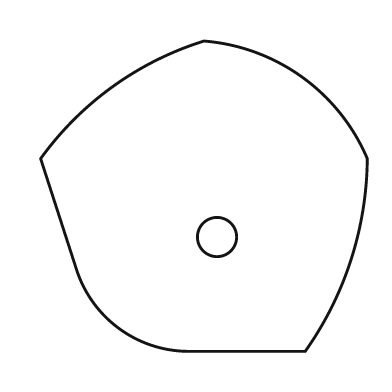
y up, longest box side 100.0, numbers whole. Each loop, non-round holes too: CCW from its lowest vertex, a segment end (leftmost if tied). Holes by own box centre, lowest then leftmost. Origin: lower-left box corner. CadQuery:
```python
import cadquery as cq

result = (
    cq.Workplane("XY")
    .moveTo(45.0, 0.0)
    .lineTo(81.0, 0.0)
    .threePointArc((95.0, 28.0), (100.0, 59.0))
    .threePointArc((80.0, 84.0), (50.0, 95.0))
    .threePointArc((22.0, 81.0), (0.0, 59.0))
    .lineTo(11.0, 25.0)
    .threePointArc((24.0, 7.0), (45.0, 0.0))
    .close()
    .moveTo(54.0, 35.0)
    .circle(6.0)
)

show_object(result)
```